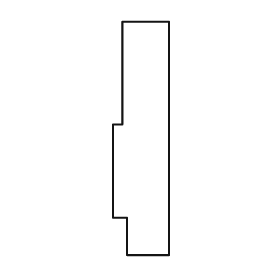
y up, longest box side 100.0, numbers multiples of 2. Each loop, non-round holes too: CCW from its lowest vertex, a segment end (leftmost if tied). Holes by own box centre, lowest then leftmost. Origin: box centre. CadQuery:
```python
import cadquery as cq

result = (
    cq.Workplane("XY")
    .moveTo(-6.0, -50.0)
    .lineTo(12.0, -50.0)
    .lineTo(12.0, 50.0)
    .lineTo(-8.0, 50.0)
    .lineTo(-8.0, 6.0)
    .lineTo(-12.0, 6.0)
    .lineTo(-12.0, -34.0)
    .lineTo(-6.0, -34.0)
    .close()
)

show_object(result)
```